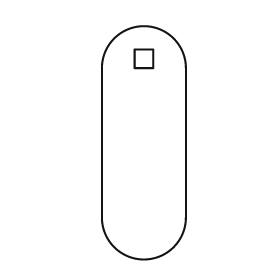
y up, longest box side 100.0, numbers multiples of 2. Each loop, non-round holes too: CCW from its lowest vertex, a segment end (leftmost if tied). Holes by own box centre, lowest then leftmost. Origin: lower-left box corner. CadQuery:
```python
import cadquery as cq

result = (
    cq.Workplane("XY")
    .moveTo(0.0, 18.0)
    .threePointArc((18.0, 0.0), (36.0, 18.0))
    .lineTo(36.0, 82.0)
    .threePointArc((18.0, 100.0), (0.0, 82.0))
    .close()
    .moveTo(14.0, 82.0)
    .lineTo(22.0, 82.0)
    .lineTo(22.0, 90.0)
    .lineTo(14.0, 90.0)
    .close()
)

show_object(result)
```